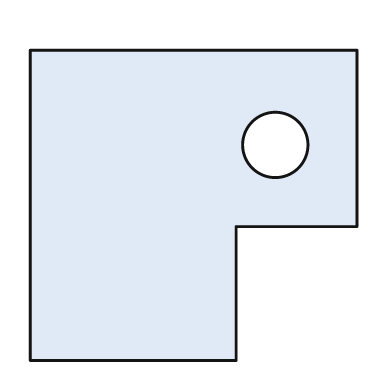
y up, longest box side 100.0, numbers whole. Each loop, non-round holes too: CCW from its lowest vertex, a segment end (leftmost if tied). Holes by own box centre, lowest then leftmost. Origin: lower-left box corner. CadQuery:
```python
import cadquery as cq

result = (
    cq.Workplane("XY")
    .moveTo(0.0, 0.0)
    .lineTo(63.0, 0.0)
    .lineTo(63.0, 41.0)
    .lineTo(100.0, 41.0)
    .lineTo(100.0, 95.0)
    .lineTo(0.0, 95.0)
    .close()
    .moveTo(75.0, 66.0)
    .circle(10.0)
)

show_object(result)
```